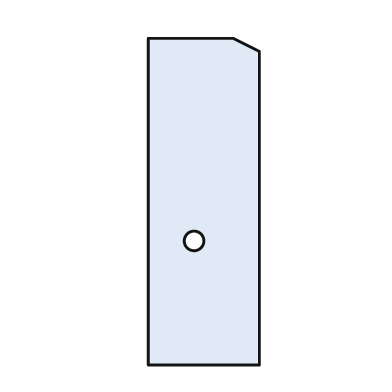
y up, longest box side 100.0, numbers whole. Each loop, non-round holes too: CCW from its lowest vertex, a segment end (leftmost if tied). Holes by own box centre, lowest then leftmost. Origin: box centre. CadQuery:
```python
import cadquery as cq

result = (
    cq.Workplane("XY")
    .moveTo(-17.0, -50.0)
    .lineTo(17.0, -50.0)
    .lineTo(17.0, 46.0)
    .lineTo(9.0, 50.0)
    .lineTo(-17.0, 50.0)
    .close()
    .moveTo(-3.0, -12.0)
    .circle(3.0)
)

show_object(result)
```